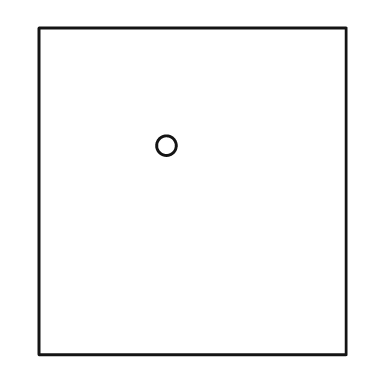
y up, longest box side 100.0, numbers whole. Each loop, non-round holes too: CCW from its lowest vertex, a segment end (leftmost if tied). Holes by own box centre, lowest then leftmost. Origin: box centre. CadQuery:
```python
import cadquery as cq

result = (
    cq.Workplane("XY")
    .moveTo(-47.0, -50.0)
    .lineTo(47.0, -50.0)
    .lineTo(47.0, 50.0)
    .lineTo(-47.0, 50.0)
    .close()
    .moveTo(-8.0, 14.0)
    .circle(3.0)
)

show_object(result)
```